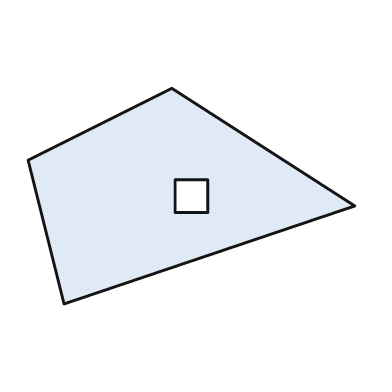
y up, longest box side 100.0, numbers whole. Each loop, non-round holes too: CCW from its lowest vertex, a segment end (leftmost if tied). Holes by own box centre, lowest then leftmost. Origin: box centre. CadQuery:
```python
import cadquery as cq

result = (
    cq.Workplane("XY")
    .moveTo(-39.0, -33.0)
    .lineTo(50.0, -3.0)
    .lineTo(-6.0, 33.0)
    .lineTo(-50.0, 11.0)
    .close()
    .moveTo(-5.0, -5.0)
    .lineTo(5.0, -5.0)
    .lineTo(5.0, 5.0)
    .lineTo(-5.0, 5.0)
    .close()
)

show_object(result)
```